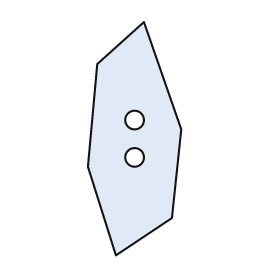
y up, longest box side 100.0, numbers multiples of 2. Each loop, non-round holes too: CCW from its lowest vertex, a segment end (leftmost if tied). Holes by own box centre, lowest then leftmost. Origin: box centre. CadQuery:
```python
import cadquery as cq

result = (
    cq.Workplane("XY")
    .moveTo(-8.0, -50.0)
    .lineTo(16.0, -34.0)
    .lineTo(20.0, 4.0)
    .lineTo(4.0, 50.0)
    .lineTo(-16.0, 32.0)
    .lineTo(-20.0, -12.0)
    .close()
    .moveTo(0.0, -8.0)
    .circle(4.0)
    .moveTo(0.0, 8.0)
    .circle(4.0)
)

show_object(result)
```